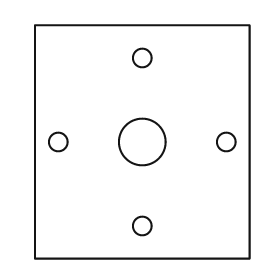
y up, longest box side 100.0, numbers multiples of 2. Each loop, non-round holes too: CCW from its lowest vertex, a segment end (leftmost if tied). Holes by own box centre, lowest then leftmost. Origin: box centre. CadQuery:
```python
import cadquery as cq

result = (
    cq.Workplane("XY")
    .moveTo(-46.0, -50.0)
    .lineTo(46.0, -50.0)
    .lineTo(46.0, 50.0)
    .lineTo(-46.0, 50.0)
    .close()
    .moveTo(0.0, -36.0)
    .circle(4.0)
    .moveTo(-36.0, 0.0)
    .circle(4.0)
    .moveTo(0.0, 0.0)
    .circle(10.0)
    .moveTo(36.0, 0.0)
    .circle(4.0)
    .moveTo(0.0, 36.0)
    .circle(4.0)
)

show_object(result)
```